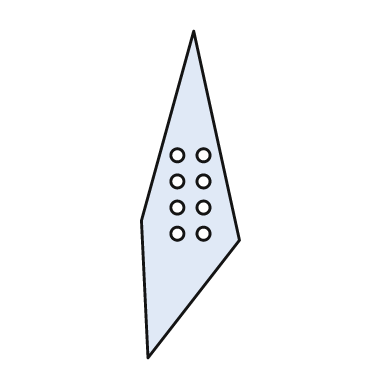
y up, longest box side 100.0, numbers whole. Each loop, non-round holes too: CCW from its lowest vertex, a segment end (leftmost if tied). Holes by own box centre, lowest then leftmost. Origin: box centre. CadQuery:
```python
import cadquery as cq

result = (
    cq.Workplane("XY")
    .moveTo(-13.0, -50.0)
    .lineTo(15.0, -14.0)
    .lineTo(1.0, 50.0)
    .lineTo(-15.0, -8.0)
    .close()
    .moveTo(-4.0, -12.0)
    .circle(2.0)
    .moveTo(4.0, -12.0)
    .circle(2.0)
    .moveTo(-4.0, -4.0)
    .circle(2.0)
    .moveTo(4.0, -4.0)
    .circle(2.0)
    .moveTo(-4.0, 4.0)
    .circle(2.0)
    .moveTo(4.0, 4.0)
    .circle(2.0)
    .moveTo(-4.0, 12.0)
    .circle(2.0)
    .moveTo(4.0, 12.0)
    .circle(2.0)
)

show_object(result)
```